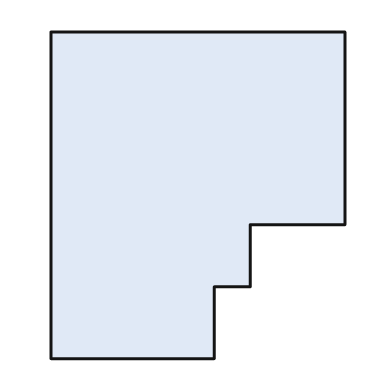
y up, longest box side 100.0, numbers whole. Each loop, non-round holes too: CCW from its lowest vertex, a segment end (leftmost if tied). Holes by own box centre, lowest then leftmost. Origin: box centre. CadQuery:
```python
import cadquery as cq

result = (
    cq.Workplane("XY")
    .moveTo(-45.0, -50.0)
    .lineTo(5.0, -50.0)
    .lineTo(5.0, -28.0)
    .lineTo(16.0, -28.0)
    .lineTo(16.0, -9.0)
    .lineTo(45.0, -9.0)
    .lineTo(45.0, 50.0)
    .lineTo(-45.0, 50.0)
    .close()
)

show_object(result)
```